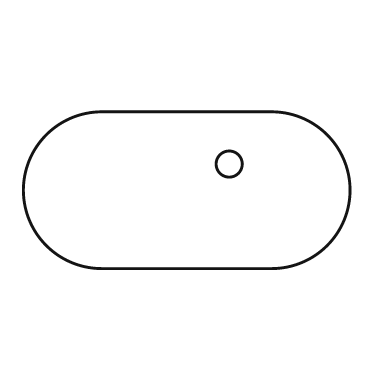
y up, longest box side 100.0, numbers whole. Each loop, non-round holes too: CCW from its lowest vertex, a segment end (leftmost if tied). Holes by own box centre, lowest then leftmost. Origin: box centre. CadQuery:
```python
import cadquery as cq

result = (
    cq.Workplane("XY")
    .moveTo(-26.0, -24.0)
    .lineTo(26.0, -24.0)
    .threePointArc((50.0, 0.0), (26.0, 24.0))
    .lineTo(-26.0, 24.0)
    .threePointArc((-50.0, 0.0), (-26.0, -24.0))
    .close()
    .moveTo(13.0, 8.0)
    .circle(4.0)
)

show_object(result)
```